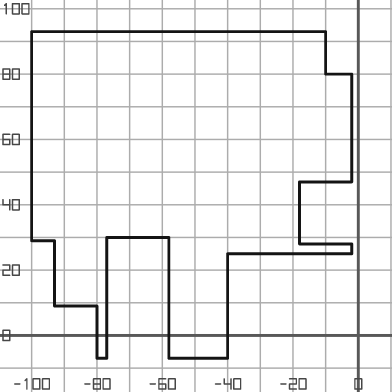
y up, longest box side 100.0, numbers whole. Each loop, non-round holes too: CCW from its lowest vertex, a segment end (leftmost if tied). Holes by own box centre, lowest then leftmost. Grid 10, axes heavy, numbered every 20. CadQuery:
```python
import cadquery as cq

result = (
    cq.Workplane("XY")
    .moveTo(-80.0, -7.0)
    .lineTo(-77.0, -7.0)
    .lineTo(-77.0, 30.0)
    .lineTo(-58.0, 30.0)
    .lineTo(-58.0, -7.0)
    .lineTo(-40.0, -7.0)
    .lineTo(-40.0, 25.0)
    .lineTo(-2.0, 25.0)
    .lineTo(-2.0, 28.0)
    .lineTo(-18.0, 28.0)
    .lineTo(-18.0, 47.0)
    .lineTo(-2.0, 47.0)
    .lineTo(-2.0, 80.0)
    .lineTo(-10.0, 80.0)
    .lineTo(-10.0, 93.0)
    .lineTo(-100.0, 93.0)
    .lineTo(-100.0, 29.0)
    .lineTo(-93.0, 29.0)
    .lineTo(-93.0, 9.0)
    .lineTo(-80.0, 9.0)
    .close()
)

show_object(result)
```